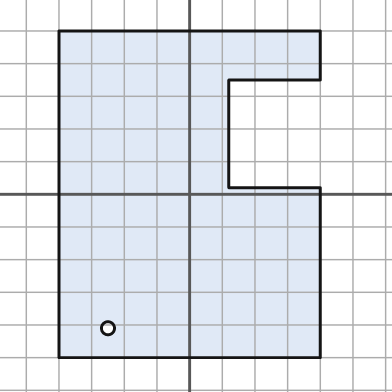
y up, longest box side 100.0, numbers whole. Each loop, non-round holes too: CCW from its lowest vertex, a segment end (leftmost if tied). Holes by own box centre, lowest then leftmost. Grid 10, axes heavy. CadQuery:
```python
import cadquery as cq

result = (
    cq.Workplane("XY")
    .moveTo(-40.0, -50.0)
    .lineTo(40.0, -50.0)
    .lineTo(40.0, 2.0)
    .lineTo(12.0, 2.0)
    .lineTo(12.0, 35.0)
    .lineTo(40.0, 35.0)
    .lineTo(40.0, 50.0)
    .lineTo(-40.0, 50.0)
    .close()
    .moveTo(-25.0, -41.0)
    .circle(2.0)
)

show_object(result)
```